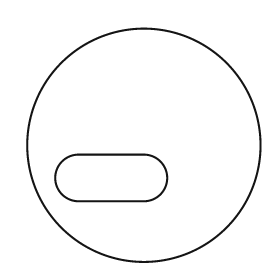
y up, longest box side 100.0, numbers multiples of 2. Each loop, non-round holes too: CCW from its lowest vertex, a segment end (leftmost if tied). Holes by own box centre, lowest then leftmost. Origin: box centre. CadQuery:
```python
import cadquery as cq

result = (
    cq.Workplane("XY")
    .moveTo(0.0, 0.0)
    .circle(50.0)
    .moveTo(-28.0, -24.0)
    .lineTo(0.0, -24.0)
    .threePointArc((10.0, -14.0), (0.0, -4.0))
    .lineTo(-28.0, -4.0)
    .threePointArc((-38.0, -14.0), (-28.0, -24.0))
    .close()
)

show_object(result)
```